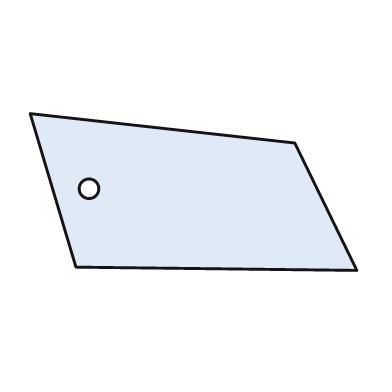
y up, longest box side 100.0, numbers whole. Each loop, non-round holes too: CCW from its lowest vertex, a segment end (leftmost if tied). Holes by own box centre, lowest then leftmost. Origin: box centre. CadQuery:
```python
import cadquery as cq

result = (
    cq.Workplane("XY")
    .moveTo(50.0, -24.0)
    .lineTo(31.0, 15.0)
    .lineTo(-50.0, 24.0)
    .lineTo(-36.0, -23.0)
    .close()
    .moveTo(-32.0, 1.0)
    .circle(3.0)
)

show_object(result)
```